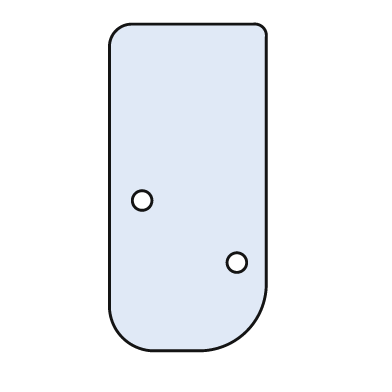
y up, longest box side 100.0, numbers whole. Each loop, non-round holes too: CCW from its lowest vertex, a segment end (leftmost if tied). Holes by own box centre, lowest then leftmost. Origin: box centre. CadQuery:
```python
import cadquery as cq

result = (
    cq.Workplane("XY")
    .moveTo(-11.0, -50.0)
    .lineTo(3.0, -50.0)
    .threePointArc((18.0, -44.0), (24.0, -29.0))
    .lineTo(24.0, 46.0)
    .threePointArc((23.0, 49.0), (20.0, 50.0))
    .lineTo(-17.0, 50.0)
    .threePointArc((-22.0, 48.0), (-24.0, 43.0))
    .lineTo(-24.0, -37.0)
    .threePointArc((-20.0, -46.0), (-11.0, -50.0))
    .close()
    .moveTo(15.0, -23.0)
    .circle(3.0)
    .moveTo(-14.0, -4.0)
    .circle(3.0)
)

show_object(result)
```